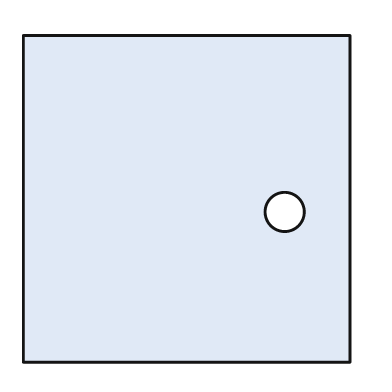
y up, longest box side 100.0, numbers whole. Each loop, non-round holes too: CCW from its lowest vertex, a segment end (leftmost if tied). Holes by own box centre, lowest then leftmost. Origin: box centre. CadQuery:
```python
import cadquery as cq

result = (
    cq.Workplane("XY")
    .moveTo(-50.0, -50.0)
    .lineTo(50.0, -50.0)
    .lineTo(50.0, 50.0)
    .lineTo(-50.0, 50.0)
    .close()
    .moveTo(30.0, -4.0)
    .circle(6.0)
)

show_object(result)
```